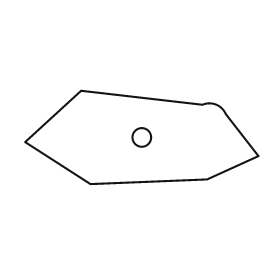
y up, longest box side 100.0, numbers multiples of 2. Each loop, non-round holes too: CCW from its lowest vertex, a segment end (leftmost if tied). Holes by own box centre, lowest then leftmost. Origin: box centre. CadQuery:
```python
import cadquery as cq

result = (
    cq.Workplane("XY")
    .moveTo(-22.0, -20.0)
    .lineTo(28.0, -18.0)
    .lineTo(50.0, -8.0)
    .lineTo(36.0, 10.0)
    .threePointArc((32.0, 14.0), (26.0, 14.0))
    .lineTo(-26.0, 20.0)
    .lineTo(-50.0, -2.0)
    .close()
    .moveTo(0.0, 0.0)
    .circle(4.0)
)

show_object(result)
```